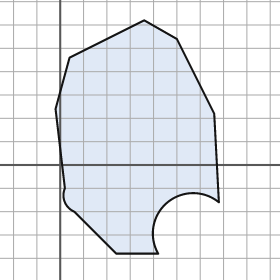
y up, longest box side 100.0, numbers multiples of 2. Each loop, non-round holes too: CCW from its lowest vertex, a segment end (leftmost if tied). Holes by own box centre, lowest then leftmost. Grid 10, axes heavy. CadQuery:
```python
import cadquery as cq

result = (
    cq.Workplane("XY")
    .moveTo(24.0, -38.0)
    .lineTo(42.0, -38.0)
    .threePointArc((46.0, -16.0), (68.0, -16.0))
    .lineTo(66.0, 22.0)
    .lineTo(50.0, 54.0)
    .lineTo(36.0, 62.0)
    .lineTo(4.0, 46.0)
    .lineTo(-2.0, 24.0)
    .lineTo(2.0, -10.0)
    .threePointArc((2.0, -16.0), (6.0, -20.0))
    .close()
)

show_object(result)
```